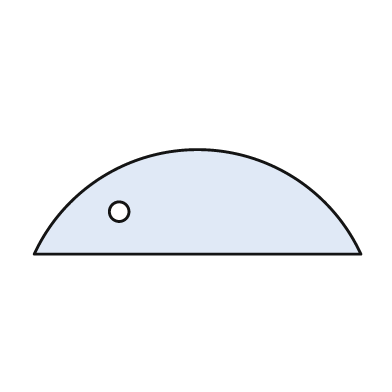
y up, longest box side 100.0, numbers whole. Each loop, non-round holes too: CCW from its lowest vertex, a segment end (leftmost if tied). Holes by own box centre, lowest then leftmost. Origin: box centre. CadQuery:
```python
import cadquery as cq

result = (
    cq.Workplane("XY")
    .moveTo(-50.0, -16.0)
    .lineTo(50.0, -16.0)
    .threePointArc((0.0, 16.0), (-50.0, -16.0))
    .close()
    .moveTo(-24.0, -3.0)
    .circle(3.0)
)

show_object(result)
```